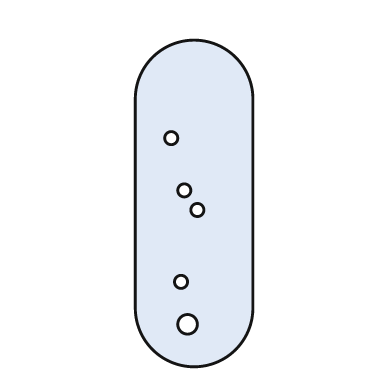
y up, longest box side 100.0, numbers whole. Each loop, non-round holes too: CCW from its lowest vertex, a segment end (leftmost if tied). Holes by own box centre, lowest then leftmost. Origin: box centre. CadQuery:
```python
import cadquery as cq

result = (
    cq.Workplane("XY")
    .moveTo(-18.0, -32.0)
    .threePointArc((0.0, -50.0), (18.0, -32.0))
    .lineTo(18.0, 32.0)
    .threePointArc((0.0, 50.0), (-18.0, 32.0))
    .close()
    .moveTo(-2.0, -37.0)
    .circle(3.0)
    .moveTo(-4.0, -24.0)
    .circle(2.0)
    .moveTo(1.0, -2.0)
    .circle(2.0)
    .moveTo(-3.0, 4.0)
    .circle(2.0)
    .moveTo(-7.0, 20.0)
    .circle(2.0)
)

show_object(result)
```